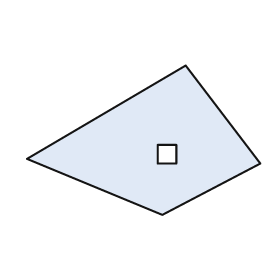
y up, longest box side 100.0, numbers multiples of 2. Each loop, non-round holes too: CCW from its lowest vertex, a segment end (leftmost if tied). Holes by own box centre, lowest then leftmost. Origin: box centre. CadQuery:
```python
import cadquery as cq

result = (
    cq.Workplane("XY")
    .moveTo(8.0, -32.0)
    .lineTo(50.0, -10.0)
    .lineTo(18.0, 32.0)
    .lineTo(-50.0, -8.0)
    .close()
    .moveTo(6.0, -10.0)
    .lineTo(14.0, -10.0)
    .lineTo(14.0, -2.0)
    .lineTo(6.0, -2.0)
    .close()
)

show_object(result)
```